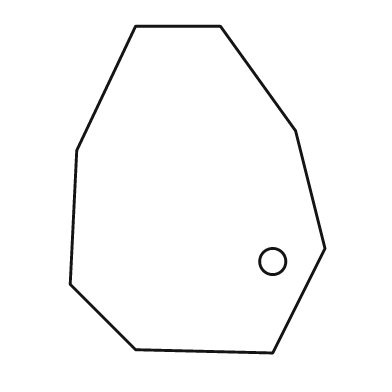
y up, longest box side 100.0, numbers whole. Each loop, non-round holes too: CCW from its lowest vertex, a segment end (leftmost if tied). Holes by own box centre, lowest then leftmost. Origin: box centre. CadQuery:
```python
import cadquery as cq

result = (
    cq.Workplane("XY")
    .moveTo(23.0, -50.0)
    .lineTo(39.0, -18.0)
    .lineTo(30.0, 18.0)
    .lineTo(7.0, 50.0)
    .lineTo(-19.0, 50.0)
    .lineTo(-37.0, 12.0)
    .lineTo(-39.0, -29.0)
    .lineTo(-19.0, -49.0)
    .close()
    .moveTo(23.0, -22.0)
    .circle(4.0)
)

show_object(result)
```